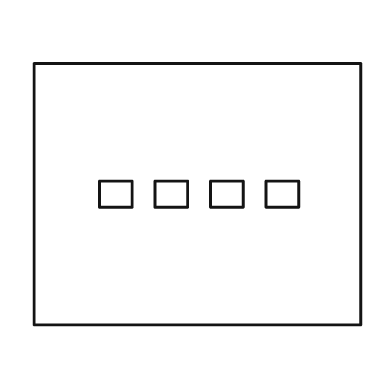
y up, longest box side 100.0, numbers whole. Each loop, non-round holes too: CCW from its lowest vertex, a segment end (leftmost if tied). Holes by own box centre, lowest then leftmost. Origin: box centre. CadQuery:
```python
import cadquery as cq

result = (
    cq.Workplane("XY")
    .moveTo(-50.0, -40.0)
    .lineTo(50.0, -40.0)
    .lineTo(50.0, 40.0)
    .lineTo(-50.0, 40.0)
    .close()
    .moveTo(-30.0, -4.0)
    .lineTo(-20.0, -4.0)
    .lineTo(-20.0, 4.0)
    .lineTo(-30.0, 4.0)
    .close()
    .moveTo(-13.0, -4.0)
    .lineTo(-3.0, -4.0)
    .lineTo(-3.0, 4.0)
    .lineTo(-13.0, 4.0)
    .close()
    .moveTo(4.0, -4.0)
    .lineTo(14.0, -4.0)
    .lineTo(14.0, 4.0)
    .lineTo(4.0, 4.0)
    .close()
    .moveTo(21.0, -4.0)
    .lineTo(31.0, -4.0)
    .lineTo(31.0, 4.0)
    .lineTo(21.0, 4.0)
    .close()
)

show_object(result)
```